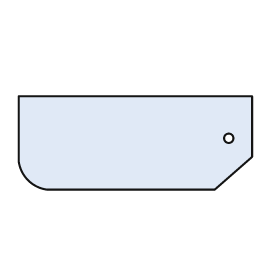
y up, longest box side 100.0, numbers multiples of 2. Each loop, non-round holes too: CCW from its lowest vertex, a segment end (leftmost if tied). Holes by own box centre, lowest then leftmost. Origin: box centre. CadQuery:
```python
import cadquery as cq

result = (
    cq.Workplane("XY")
    .moveTo(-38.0, -20.0)
    .lineTo(34.0, -20.0)
    .lineTo(50.0, -6.0)
    .lineTo(50.0, 20.0)
    .lineTo(-50.0, 20.0)
    .lineTo(-50.0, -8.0)
    .threePointArc((-46.0, -16.0), (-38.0, -20.0))
    .close()
    .moveTo(40.0, 2.0)
    .circle(2.0)
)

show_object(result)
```